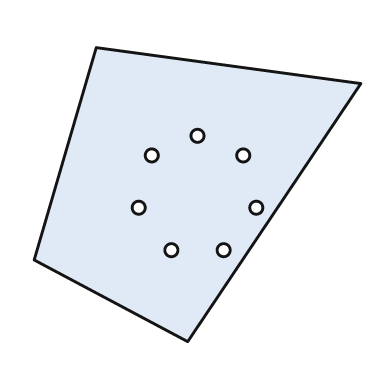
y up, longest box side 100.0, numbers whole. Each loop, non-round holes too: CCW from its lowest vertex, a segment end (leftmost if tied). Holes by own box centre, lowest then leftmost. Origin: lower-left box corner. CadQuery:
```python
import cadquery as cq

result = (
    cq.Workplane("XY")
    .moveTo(47.0, 0.0)
    .lineTo(100.0, 79.0)
    .lineTo(19.0, 90.0)
    .lineTo(0.0, 25.0)
    .close()
    .moveTo(42.0, 28.0)
    .circle(2.0)
    .moveTo(58.0, 28.0)
    .circle(2.0)
    .moveTo(32.0, 41.0)
    .circle(2.0)
    .moveTo(68.0, 41.0)
    .circle(2.0)
    .moveTo(36.0, 57.0)
    .circle(2.0)
    .moveTo(64.0, 57.0)
    .circle(2.0)
    .moveTo(50.0, 63.0)
    .circle(2.0)
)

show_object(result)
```